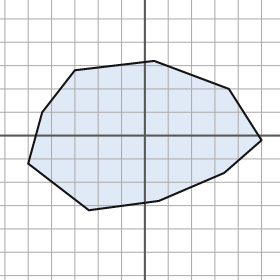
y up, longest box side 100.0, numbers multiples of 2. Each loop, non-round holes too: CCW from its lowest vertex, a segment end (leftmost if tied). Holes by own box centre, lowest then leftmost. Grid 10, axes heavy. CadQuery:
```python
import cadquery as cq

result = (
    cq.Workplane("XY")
    .moveTo(-24.0, -32.0)
    .lineTo(6.0, -28.0)
    .lineTo(34.0, -16.0)
    .lineTo(50.0, -2.0)
    .lineTo(36.0, 20.0)
    .lineTo(4.0, 32.0)
    .lineTo(-30.0, 28.0)
    .lineTo(-44.0, 10.0)
    .lineTo(-50.0, -12.0)
    .close()
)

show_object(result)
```